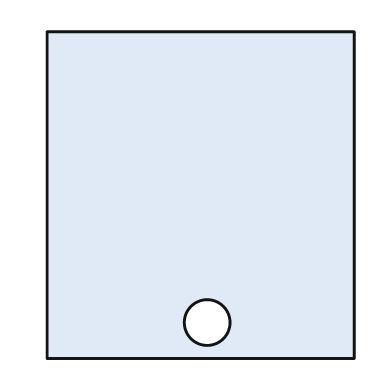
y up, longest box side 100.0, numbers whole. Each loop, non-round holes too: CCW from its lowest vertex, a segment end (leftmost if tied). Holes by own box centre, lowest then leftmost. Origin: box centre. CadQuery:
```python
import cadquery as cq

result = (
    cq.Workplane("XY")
    .moveTo(-47.0, -50.0)
    .lineTo(47.0, -50.0)
    .lineTo(47.0, 50.0)
    .lineTo(-47.0, 50.0)
    .close()
    .moveTo(2.0, -39.0)
    .circle(7.0)
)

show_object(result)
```